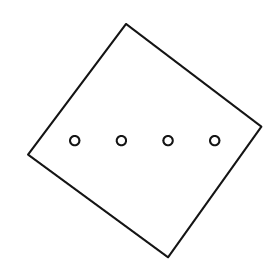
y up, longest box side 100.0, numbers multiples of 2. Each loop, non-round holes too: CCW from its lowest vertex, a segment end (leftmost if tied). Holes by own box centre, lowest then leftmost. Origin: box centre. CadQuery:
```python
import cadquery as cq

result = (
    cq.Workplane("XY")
    .moveTo(10.0, -50.0)
    .lineTo(50.0, 6.0)
    .lineTo(-8.0, 50.0)
    .lineTo(-50.0, -6.0)
    .close()
    .moveTo(-30.0, 0.0)
    .circle(2.0)
    .moveTo(-10.0, 0.0)
    .circle(2.0)
    .moveTo(10.0, 0.0)
    .circle(2.0)
    .moveTo(30.0, 0.0)
    .circle(2.0)
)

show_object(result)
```